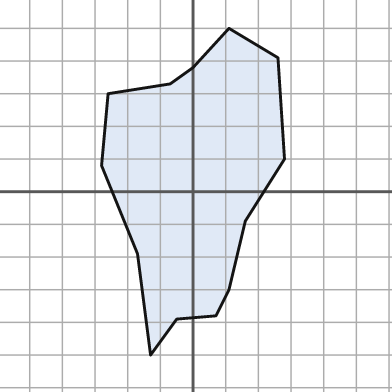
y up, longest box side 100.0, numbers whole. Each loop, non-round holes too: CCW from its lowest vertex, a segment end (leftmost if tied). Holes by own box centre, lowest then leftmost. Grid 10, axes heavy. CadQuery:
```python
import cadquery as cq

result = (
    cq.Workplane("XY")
    .moveTo(-13.0, -50.0)
    .lineTo(-5.0, -39.0)
    .lineTo(7.0, -38.0)
    .lineTo(11.0, -30.0)
    .lineTo(16.0, -9.0)
    .lineTo(28.0, 10.0)
    .lineTo(26.0, 41.0)
    .lineTo(11.0, 50.0)
    .lineTo(0.0, 38.0)
    .lineTo(-7.0, 33.0)
    .lineTo(-26.0, 30.0)
    .lineTo(-28.0, 8.0)
    .lineTo(-17.0, -19.0)
    .close()
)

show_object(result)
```